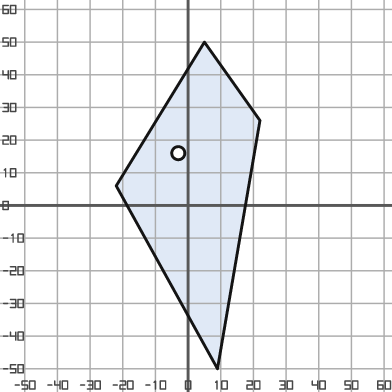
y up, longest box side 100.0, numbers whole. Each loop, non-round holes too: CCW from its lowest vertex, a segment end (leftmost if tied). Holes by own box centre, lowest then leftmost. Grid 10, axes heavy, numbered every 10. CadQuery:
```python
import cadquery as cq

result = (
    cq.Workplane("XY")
    .moveTo(9.0, -50.0)
    .lineTo(22.0, 26.0)
    .lineTo(5.0, 50.0)
    .lineTo(-22.0, 6.0)
    .close()
    .moveTo(-3.0, 16.0)
    .circle(2.0)
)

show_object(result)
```